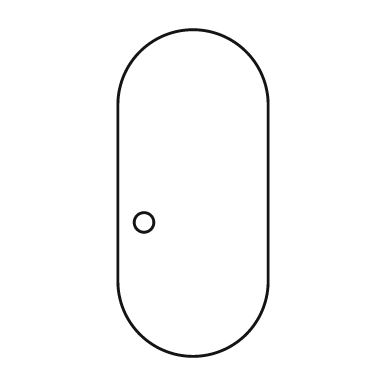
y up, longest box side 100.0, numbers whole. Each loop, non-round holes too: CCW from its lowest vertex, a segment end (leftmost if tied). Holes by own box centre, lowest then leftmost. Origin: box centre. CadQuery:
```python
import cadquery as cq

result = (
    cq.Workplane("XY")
    .moveTo(-23.0, -27.0)
    .threePointArc((0.0, -50.0), (23.0, -27.0))
    .lineTo(23.0, 27.0)
    .threePointArc((0.0, 50.0), (-23.0, 27.0))
    .close()
    .moveTo(-15.0, -9.0)
    .circle(3.0)
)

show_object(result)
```